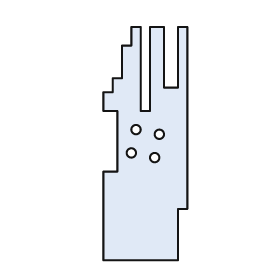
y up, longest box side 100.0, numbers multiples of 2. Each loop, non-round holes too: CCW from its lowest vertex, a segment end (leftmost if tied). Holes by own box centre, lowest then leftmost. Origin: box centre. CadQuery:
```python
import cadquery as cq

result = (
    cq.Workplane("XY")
    .moveTo(-18.0, -50.0)
    .lineTo(14.0, -50.0)
    .lineTo(14.0, -28.0)
    .lineTo(18.0, -28.0)
    .lineTo(18.0, 50.0)
    .lineTo(14.0, 50.0)
    .lineTo(14.0, 24.0)
    .lineTo(8.0, 24.0)
    .lineTo(8.0, 50.0)
    .lineTo(2.0, 50.0)
    .lineTo(2.0, 14.0)
    .lineTo(-2.0, 14.0)
    .lineTo(-2.0, 50.0)
    .lineTo(-6.0, 50.0)
    .lineTo(-6.0, 42.0)
    .lineTo(-10.0, 42.0)
    .lineTo(-10.0, 28.0)
    .lineTo(-14.0, 28.0)
    .lineTo(-14.0, 22.0)
    .lineTo(-18.0, 22.0)
    .lineTo(-18.0, 14.0)
    .lineTo(-12.0, 14.0)
    .lineTo(-12.0, -12.0)
    .lineTo(-18.0, -12.0)
    .close()
    .moveTo(4.0, -6.0)
    .circle(2.0)
    .moveTo(-6.0, -4.0)
    .circle(2.0)
    .moveTo(6.0, 4.0)
    .circle(2.0)
    .moveTo(-4.0, 6.0)
    .circle(2.0)
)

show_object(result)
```